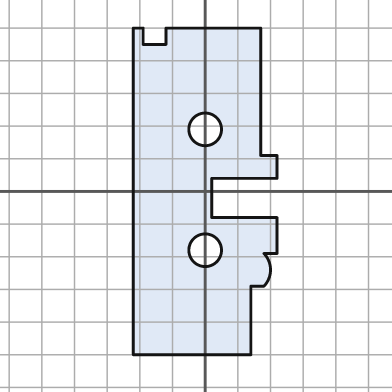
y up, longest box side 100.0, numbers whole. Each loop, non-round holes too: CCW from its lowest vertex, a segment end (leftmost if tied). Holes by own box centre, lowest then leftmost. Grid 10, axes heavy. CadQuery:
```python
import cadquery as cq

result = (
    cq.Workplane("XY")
    .moveTo(-22.0, -50.0)
    .lineTo(14.0, -50.0)
    .lineTo(14.0, -29.0)
    .lineTo(18.0, -29.0)
    .threePointArc((20.0, -24.0), (18.0, -19.0))
    .lineTo(22.0, -19.0)
    .lineTo(22.0, -8.0)
    .lineTo(2.0, -8.0)
    .lineTo(2.0, 4.0)
    .lineTo(22.0, 4.0)
    .lineTo(22.0, 11.0)
    .lineTo(17.0, 11.0)
    .lineTo(17.0, 50.0)
    .lineTo(-12.0, 50.0)
    .lineTo(-12.0, 45.0)
    .lineTo(-19.0, 45.0)
    .lineTo(-19.0, 50.0)
    .lineTo(-22.0, 50.0)
    .close()
    .moveTo(0.0, -18.0)
    .circle(5.0)
    .moveTo(0.0, 19.0)
    .circle(5.0)
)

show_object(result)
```